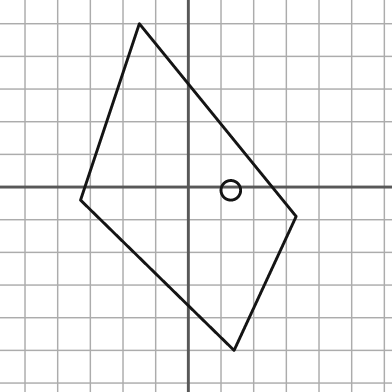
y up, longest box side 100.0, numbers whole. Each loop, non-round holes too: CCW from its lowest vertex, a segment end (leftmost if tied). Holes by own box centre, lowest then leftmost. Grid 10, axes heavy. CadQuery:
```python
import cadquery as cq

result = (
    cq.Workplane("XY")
    .moveTo(14.0, -50.0)
    .lineTo(33.0, -9.0)
    .lineTo(-15.0, 50.0)
    .lineTo(-33.0, -4.0)
    .close()
    .moveTo(13.0, -1.0)
    .circle(3.0)
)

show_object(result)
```